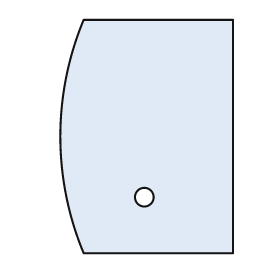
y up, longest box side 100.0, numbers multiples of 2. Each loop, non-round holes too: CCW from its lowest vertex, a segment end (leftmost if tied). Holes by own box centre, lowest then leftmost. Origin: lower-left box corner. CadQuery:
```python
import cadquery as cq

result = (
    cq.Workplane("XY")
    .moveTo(10.0, 0.0)
    .lineTo(74.0, 0.0)
    .lineTo(74.0, 100.0)
    .lineTo(10.0, 100.0)
    .threePointArc((0.0, 50.0), (10.0, 0.0))
    .close()
    .moveTo(36.0, 24.0)
    .circle(4.0)
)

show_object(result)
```